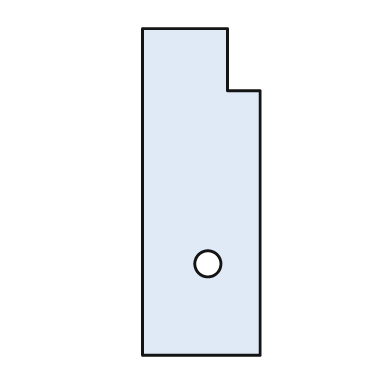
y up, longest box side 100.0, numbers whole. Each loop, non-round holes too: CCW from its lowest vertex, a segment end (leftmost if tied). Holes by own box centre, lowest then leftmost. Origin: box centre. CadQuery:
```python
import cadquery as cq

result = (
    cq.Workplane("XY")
    .moveTo(-18.0, -50.0)
    .lineTo(18.0, -50.0)
    .lineTo(18.0, 31.0)
    .lineTo(8.0, 31.0)
    .lineTo(8.0, 50.0)
    .lineTo(-18.0, 50.0)
    .close()
    .moveTo(2.0, -22.0)
    .circle(4.0)
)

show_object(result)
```